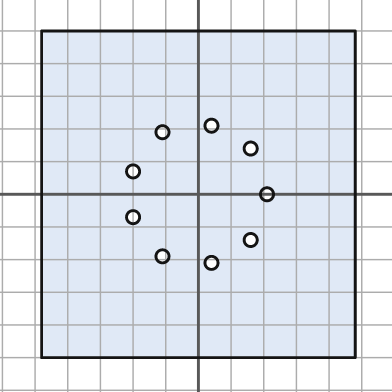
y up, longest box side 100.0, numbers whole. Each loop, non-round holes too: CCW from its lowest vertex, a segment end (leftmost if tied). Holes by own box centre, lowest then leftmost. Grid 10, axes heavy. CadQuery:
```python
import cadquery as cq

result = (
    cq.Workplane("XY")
    .moveTo(-48.0, -50.0)
    .lineTo(48.0, -50.0)
    .lineTo(48.0, 50.0)
    .lineTo(-48.0, 50.0)
    .close()
    .moveTo(4.0, -21.0)
    .circle(2.0)
    .moveTo(-11.0, -19.0)
    .circle(2.0)
    .moveTo(16.0, -14.0)
    .circle(2.0)
    .moveTo(-20.0, -7.0)
    .circle(2.0)
    .moveTo(21.0, 0.0)
    .circle(2.0)
    .moveTo(-20.0, 7.0)
    .circle(2.0)
    .moveTo(16.0, 14.0)
    .circle(2.0)
    .moveTo(-11.0, 19.0)
    .circle(2.0)
    .moveTo(4.0, 21.0)
    .circle(2.0)
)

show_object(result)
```